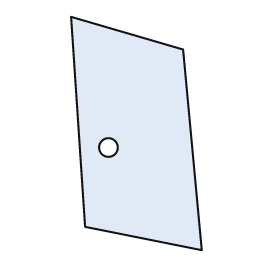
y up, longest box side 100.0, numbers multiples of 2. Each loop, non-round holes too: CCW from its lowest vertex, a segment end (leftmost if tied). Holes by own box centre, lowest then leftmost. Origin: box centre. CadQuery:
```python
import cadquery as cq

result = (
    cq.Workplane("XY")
    .moveTo(28.0, -50.0)
    .lineTo(20.0, 36.0)
    .lineTo(-28.0, 50.0)
    .lineTo(-22.0, -40.0)
    .close()
    .moveTo(-12.0, -6.0)
    .circle(4.0)
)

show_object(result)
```